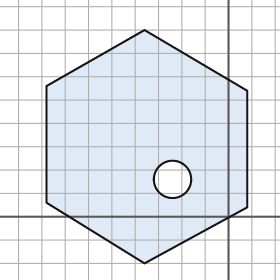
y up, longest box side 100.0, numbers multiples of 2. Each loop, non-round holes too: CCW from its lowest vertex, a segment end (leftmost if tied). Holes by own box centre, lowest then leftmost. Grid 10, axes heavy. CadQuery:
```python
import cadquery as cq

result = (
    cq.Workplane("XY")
    .moveTo(-36.0, -20.0)
    .lineTo(8.0, 4.0)
    .lineTo(8.0, 54.0)
    .lineTo(-36.0, 80.0)
    .lineTo(-78.0, 56.0)
    .lineTo(-78.0, 6.0)
    .close()
    .moveTo(-24.0, 16.0)
    .circle(8.0)
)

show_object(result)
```